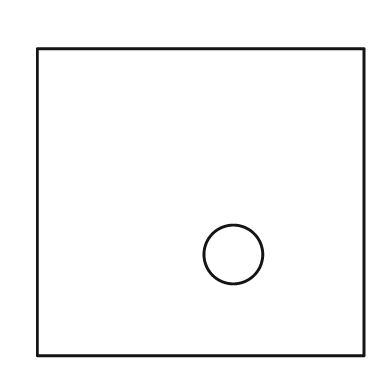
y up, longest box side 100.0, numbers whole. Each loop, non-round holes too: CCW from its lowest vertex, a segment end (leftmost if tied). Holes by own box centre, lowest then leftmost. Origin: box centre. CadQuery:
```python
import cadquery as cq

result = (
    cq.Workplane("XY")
    .moveTo(-50.0, -47.0)
    .lineTo(50.0, -47.0)
    .lineTo(50.0, 47.0)
    .lineTo(-50.0, 47.0)
    .close()
    .moveTo(10.0, -16.0)
    .circle(9.0)
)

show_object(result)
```